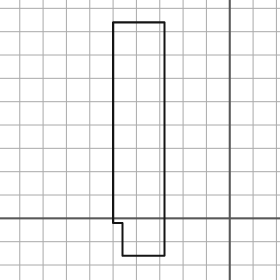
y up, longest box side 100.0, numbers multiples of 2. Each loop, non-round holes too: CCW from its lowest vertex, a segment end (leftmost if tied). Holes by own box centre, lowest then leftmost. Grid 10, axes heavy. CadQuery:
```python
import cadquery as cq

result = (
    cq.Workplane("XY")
    .moveTo(-46.0, -16.0)
    .lineTo(-28.0, -16.0)
    .lineTo(-28.0, 84.0)
    .lineTo(-50.0, 84.0)
    .lineTo(-50.0, -2.0)
    .lineTo(-46.0, -2.0)
    .close()
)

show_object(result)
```